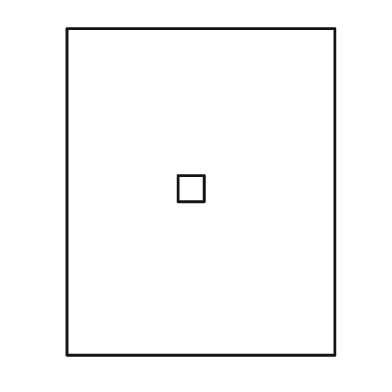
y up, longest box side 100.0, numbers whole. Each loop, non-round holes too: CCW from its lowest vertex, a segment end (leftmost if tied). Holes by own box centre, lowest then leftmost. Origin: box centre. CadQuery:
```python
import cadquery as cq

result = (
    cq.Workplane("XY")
    .moveTo(-41.0, -50.0)
    .lineTo(41.0, -50.0)
    .lineTo(41.0, 50.0)
    .lineTo(-41.0, 50.0)
    .close()
    .moveTo(-7.0, -3.0)
    .lineTo(1.0, -3.0)
    .lineTo(1.0, 5.0)
    .lineTo(-7.0, 5.0)
    .close()
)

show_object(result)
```